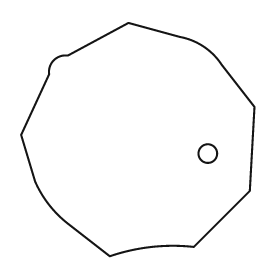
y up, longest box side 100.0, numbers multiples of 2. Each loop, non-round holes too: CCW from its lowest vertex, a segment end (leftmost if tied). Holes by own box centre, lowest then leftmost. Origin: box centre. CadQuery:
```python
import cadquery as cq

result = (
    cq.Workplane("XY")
    .moveTo(-12.0, -50.0)
    .threePointArc((6.0, -46.0), (24.0, -46.0))
    .lineTo(48.0, -22.0)
    .lineTo(50.0, 14.0)
    .lineTo(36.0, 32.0)
    .threePointArc((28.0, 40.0), (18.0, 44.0))
    .lineTo(-4.0, 50.0)
    .lineTo(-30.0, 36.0)
    .threePointArc((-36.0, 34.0), (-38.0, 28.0))
    .lineTo(-50.0, 2.0)
    .lineTo(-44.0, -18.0)
    .threePointArc((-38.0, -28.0), (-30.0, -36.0))
    .close()
    .moveTo(30.0, -6.0)
    .circle(4.0)
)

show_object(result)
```